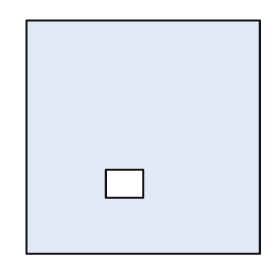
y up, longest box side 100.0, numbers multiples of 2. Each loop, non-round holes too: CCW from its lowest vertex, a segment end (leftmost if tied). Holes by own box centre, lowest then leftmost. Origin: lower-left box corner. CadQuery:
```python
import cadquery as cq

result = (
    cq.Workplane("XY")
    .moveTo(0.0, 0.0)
    .lineTo(100.0, 0.0)
    .lineTo(100.0, 100.0)
    .lineTo(0.0, 100.0)
    .close()
    .moveTo(34.0, 24.0)
    .lineTo(50.0, 24.0)
    .lineTo(50.0, 36.0)
    .lineTo(34.0, 36.0)
    .close()
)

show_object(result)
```